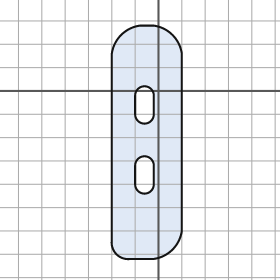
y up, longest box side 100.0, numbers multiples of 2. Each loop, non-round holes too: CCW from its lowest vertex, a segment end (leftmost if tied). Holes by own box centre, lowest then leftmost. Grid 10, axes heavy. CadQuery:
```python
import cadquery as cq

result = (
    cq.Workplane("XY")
    .moveTo(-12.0, -72.0)
    .lineTo(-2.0, -72.0)
    .threePointArc((6.0, -68.0), (10.0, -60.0))
    .lineTo(10.0, 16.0)
    .threePointArc((6.0, 24.0), (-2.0, 28.0))
    .lineTo(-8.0, 28.0)
    .threePointArc((-16.0, 24.0), (-20.0, 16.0))
    .lineTo(-20.0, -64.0)
    .threePointArc((-18.0, -70.0), (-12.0, -72.0))
    .close()
    .moveTo(-10.0, -40.0)
    .threePointArc((-6.0, -44.0), (-2.0, -40.0))
    .lineTo(-2.0, -32.0)
    .threePointArc((-6.0, -28.0), (-10.0, -32.0))
    .close()
    .moveTo(-10.0, -10.0)
    .threePointArc((-6.0, -14.0), (-2.0, -10.0))
    .lineTo(-2.0, -2.0)
    .threePointArc((-6.0, 2.0), (-10.0, -2.0))
    .close()
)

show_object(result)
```